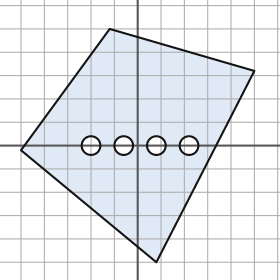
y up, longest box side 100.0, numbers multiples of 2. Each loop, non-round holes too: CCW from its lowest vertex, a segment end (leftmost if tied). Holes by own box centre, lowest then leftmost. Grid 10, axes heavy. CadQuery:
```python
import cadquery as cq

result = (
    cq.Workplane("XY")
    .moveTo(8.0, -50.0)
    .lineTo(50.0, 32.0)
    .lineTo(-12.0, 50.0)
    .lineTo(-50.0, -2.0)
    .close()
    .moveTo(-20.0, 0.0)
    .circle(4.0)
    .moveTo(-6.0, 0.0)
    .circle(4.0)
    .moveTo(8.0, 0.0)
    .circle(4.0)
    .moveTo(22.0, 0.0)
    .circle(4.0)
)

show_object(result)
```